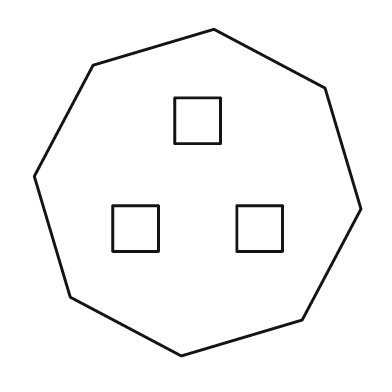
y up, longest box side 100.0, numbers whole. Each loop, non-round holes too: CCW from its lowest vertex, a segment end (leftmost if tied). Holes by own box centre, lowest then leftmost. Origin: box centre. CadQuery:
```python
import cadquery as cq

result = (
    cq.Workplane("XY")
    .moveTo(-5.0, -50.0)
    .lineTo(32.0, -39.0)
    .lineTo(50.0, -5.0)
    .lineTo(39.0, 32.0)
    .lineTo(5.0, 50.0)
    .lineTo(-32.0, 39.0)
    .lineTo(-50.0, 5.0)
    .lineTo(-39.0, -32.0)
    .close()
    .moveTo(-26.0, -18.0)
    .lineTo(-12.0, -18.0)
    .lineTo(-12.0, -4.0)
    .lineTo(-26.0, -4.0)
    .close()
    .moveTo(12.0, -18.0)
    .lineTo(26.0, -18.0)
    .lineTo(26.0, -4.0)
    .lineTo(12.0, -4.0)
    .close()
    .moveTo(-7.0, 15.0)
    .lineTo(7.0, 15.0)
    .lineTo(7.0, 29.0)
    .lineTo(-7.0, 29.0)
    .close()
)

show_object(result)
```